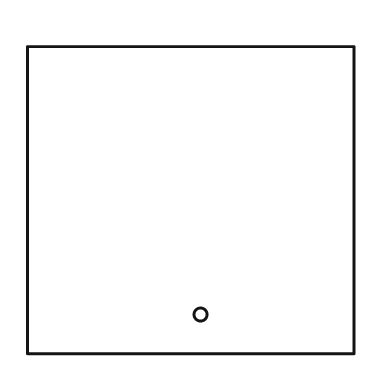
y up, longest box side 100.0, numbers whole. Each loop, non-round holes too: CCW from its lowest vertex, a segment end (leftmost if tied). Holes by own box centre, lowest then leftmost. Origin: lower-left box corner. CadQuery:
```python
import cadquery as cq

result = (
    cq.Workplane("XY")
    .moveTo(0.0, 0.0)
    .lineTo(100.0, 0.0)
    .lineTo(100.0, 94.0)
    .lineTo(0.0, 94.0)
    .close()
    .moveTo(53.0, 12.0)
    .circle(2.0)
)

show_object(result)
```